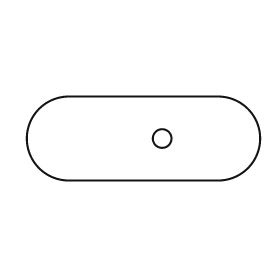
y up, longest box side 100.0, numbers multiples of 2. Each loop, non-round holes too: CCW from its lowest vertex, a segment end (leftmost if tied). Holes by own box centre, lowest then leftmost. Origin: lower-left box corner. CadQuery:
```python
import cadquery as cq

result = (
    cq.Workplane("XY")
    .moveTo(18.0, 0.0)
    .lineTo(82.0, 0.0)
    .threePointArc((100.0, 18.0), (82.0, 36.0))
    .lineTo(18.0, 36.0)
    .threePointArc((0.0, 18.0), (18.0, 0.0))
    .close()
    .moveTo(58.0, 18.0)
    .circle(4.0)
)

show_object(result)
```